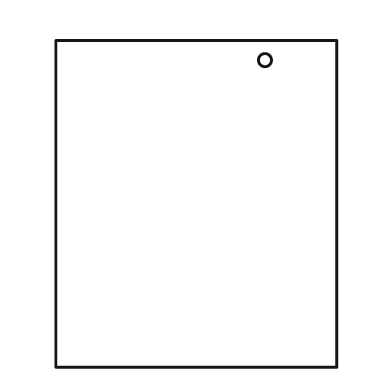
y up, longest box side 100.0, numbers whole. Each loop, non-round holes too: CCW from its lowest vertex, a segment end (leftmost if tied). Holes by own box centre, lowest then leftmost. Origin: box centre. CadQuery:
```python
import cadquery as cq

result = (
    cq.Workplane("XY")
    .moveTo(-43.0, -50.0)
    .lineTo(43.0, -50.0)
    .lineTo(43.0, 50.0)
    .lineTo(-43.0, 50.0)
    .close()
    .moveTo(21.0, 44.0)
    .circle(2.0)
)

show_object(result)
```